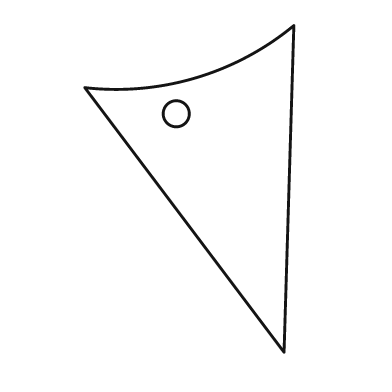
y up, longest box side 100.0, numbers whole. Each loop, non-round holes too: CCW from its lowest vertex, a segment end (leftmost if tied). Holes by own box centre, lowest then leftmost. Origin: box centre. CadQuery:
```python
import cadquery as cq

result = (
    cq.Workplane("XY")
    .moveTo(29.0, -50.0)
    .lineTo(32.0, 50.0)
    .threePointArc((2.0, 34.0), (-32.0, 31.0))
    .close()
    .moveTo(-4.0, 23.0)
    .circle(4.0)
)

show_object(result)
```